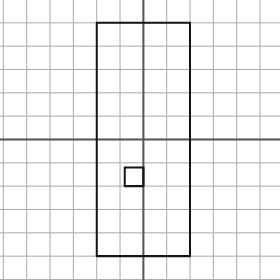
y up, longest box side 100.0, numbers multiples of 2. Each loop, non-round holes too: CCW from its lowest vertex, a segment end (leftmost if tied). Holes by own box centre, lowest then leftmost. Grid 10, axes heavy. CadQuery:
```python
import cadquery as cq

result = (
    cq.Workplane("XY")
    .moveTo(-20.0, -50.0)
    .lineTo(20.0, -50.0)
    .lineTo(20.0, 50.0)
    .lineTo(-20.0, 50.0)
    .close()
    .moveTo(-8.0, -20.0)
    .lineTo(0.0, -20.0)
    .lineTo(0.0, -12.0)
    .lineTo(-8.0, -12.0)
    .close()
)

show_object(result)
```